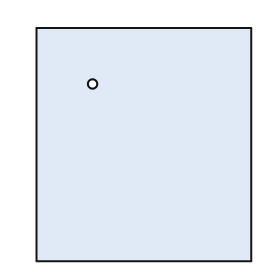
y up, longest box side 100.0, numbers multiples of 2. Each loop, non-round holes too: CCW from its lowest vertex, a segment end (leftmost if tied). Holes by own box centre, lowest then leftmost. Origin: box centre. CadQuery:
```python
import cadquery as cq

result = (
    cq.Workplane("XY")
    .moveTo(-46.0, -50.0)
    .lineTo(46.0, -50.0)
    .lineTo(46.0, 50.0)
    .lineTo(-46.0, 50.0)
    .close()
    .moveTo(-22.0, 26.0)
    .circle(2.0)
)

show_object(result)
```